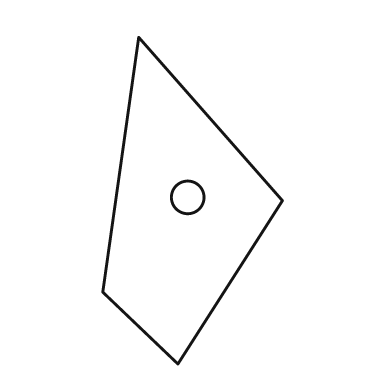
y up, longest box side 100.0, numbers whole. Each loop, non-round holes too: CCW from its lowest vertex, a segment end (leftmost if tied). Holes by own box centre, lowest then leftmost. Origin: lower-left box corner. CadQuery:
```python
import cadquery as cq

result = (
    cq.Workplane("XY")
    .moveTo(23.0, 0.0)
    .lineTo(55.0, 50.0)
    .lineTo(11.0, 100.0)
    .lineTo(0.0, 22.0)
    .close()
    .moveTo(26.0, 51.0)
    .circle(5.0)
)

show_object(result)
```